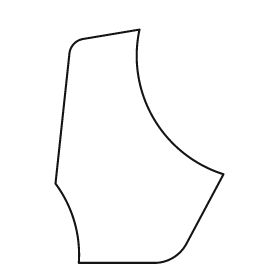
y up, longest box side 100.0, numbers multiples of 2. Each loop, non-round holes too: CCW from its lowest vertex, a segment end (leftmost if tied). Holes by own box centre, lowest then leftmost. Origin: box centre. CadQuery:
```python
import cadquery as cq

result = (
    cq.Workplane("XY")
    .moveTo(-26.0, -50.0)
    .lineTo(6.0, -50.0)
    .threePointArc((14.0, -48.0), (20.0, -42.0))
    .lineTo(36.0, -12.0)
    .threePointArc((6.0, 12.0), (0.0, 50.0))
    .lineTo(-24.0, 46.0)
    .threePointArc((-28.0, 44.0), (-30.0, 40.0))
    .lineTo(-36.0, -16.0)
    .threePointArc((-28.0, -32.0), (-26.0, -50.0))
    .close()
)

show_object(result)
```